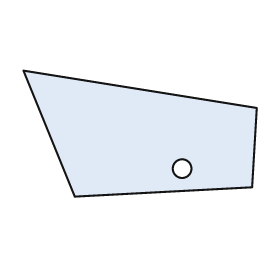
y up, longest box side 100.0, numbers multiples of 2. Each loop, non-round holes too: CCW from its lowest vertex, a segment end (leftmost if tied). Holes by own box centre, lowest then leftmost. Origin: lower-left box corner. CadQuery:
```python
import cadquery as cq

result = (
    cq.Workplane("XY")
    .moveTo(22.0, 0.0)
    .lineTo(98.0, 4.0)
    .lineTo(100.0, 38.0)
    .lineTo(0.0, 54.0)
    .close()
    .moveTo(68.0, 12.0)
    .circle(4.0)
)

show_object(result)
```